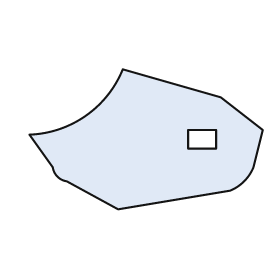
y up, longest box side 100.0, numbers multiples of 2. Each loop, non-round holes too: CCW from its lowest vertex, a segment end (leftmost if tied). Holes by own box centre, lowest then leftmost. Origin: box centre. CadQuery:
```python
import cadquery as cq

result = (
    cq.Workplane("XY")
    .moveTo(-12.0, -30.0)
    .lineTo(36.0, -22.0)
    .threePointArc((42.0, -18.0), (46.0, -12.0))
    .lineTo(50.0, 4.0)
    .lineTo(32.0, 18.0)
    .lineTo(-10.0, 30.0)
    .threePointArc((-26.0, 10.0), (-50.0, 2.0))
    .lineTo(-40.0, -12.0)
    .threePointArc((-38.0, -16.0), (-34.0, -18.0))
    .close()
    .moveTo(18.0, -4.0)
    .lineTo(30.0, -4.0)
    .lineTo(30.0, 4.0)
    .lineTo(18.0, 4.0)
    .close()
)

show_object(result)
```